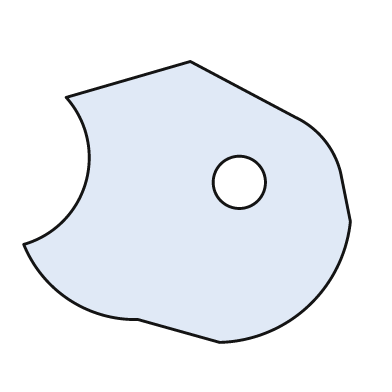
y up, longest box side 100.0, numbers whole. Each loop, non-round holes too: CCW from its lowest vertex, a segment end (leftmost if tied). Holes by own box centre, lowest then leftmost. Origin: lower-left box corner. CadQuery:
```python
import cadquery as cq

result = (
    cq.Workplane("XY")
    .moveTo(60.0, 0.0)
    .threePointArc((87.0, 11.0), (100.0, 37.0))
    .lineTo(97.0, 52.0)
    .threePointArc((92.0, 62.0), (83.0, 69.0))
    .lineTo(51.0, 86.0)
    .lineTo(13.0, 75.0)
    .threePointArc((19.0, 49.0), (0.0, 30.0))
    .threePointArc((14.0, 13.0), (35.0, 7.0))
    .close()
    .moveTo(66.0, 49.0)
    .circle(8.0)
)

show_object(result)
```